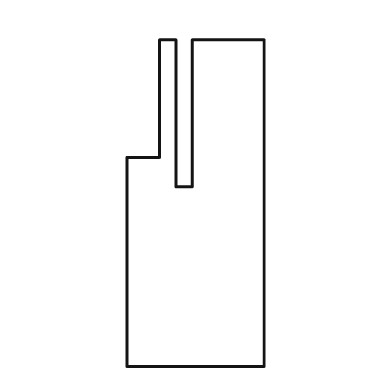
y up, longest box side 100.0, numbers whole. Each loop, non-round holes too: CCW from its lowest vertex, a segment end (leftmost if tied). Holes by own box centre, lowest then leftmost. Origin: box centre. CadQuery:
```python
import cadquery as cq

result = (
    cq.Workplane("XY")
    .moveTo(-21.0, -50.0)
    .lineTo(21.0, -50.0)
    .lineTo(21.0, 50.0)
    .lineTo(-1.0, 50.0)
    .lineTo(-1.0, 5.0)
    .lineTo(-6.0, 5.0)
    .lineTo(-6.0, 50.0)
    .lineTo(-11.0, 50.0)
    .lineTo(-11.0, 14.0)
    .lineTo(-21.0, 14.0)
    .close()
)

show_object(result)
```